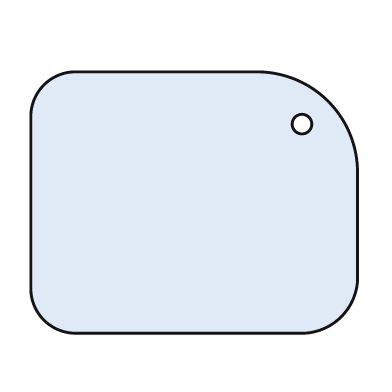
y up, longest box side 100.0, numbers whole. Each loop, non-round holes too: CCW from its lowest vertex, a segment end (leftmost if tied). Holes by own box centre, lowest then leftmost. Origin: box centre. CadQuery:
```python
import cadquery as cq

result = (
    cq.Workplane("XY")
    .moveTo(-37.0, -40.0)
    .lineTo(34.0, -40.0)
    .threePointArc((45.0, -35.0), (50.0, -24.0))
    .lineTo(50.0, 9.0)
    .threePointArc((41.0, 31.0), (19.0, 40.0))
    .lineTo(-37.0, 40.0)
    .threePointArc((-46.0, 36.0), (-50.0, 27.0))
    .lineTo(-50.0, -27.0)
    .threePointArc((-46.0, -36.0), (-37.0, -40.0))
    .close()
    .moveTo(33.0, 24.0)
    .circle(3.0)
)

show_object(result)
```